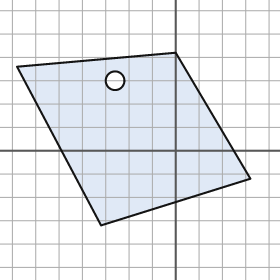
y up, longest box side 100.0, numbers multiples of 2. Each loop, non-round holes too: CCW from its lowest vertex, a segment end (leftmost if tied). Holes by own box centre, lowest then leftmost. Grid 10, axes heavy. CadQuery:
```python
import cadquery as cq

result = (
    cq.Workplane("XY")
    .moveTo(-32.0, -32.0)
    .lineTo(32.0, -12.0)
    .lineTo(0.0, 42.0)
    .lineTo(-68.0, 36.0)
    .close()
    .moveTo(-26.0, 30.0)
    .circle(4.0)
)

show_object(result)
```